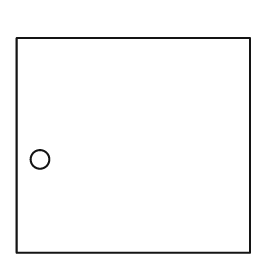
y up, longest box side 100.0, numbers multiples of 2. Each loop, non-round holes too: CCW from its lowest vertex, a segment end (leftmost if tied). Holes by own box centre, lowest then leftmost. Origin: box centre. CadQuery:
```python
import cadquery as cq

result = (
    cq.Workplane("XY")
    .moveTo(-50.0, -46.0)
    .lineTo(50.0, -46.0)
    .lineTo(50.0, 46.0)
    .lineTo(-50.0, 46.0)
    .close()
    .moveTo(-40.0, -6.0)
    .circle(4.0)
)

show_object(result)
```